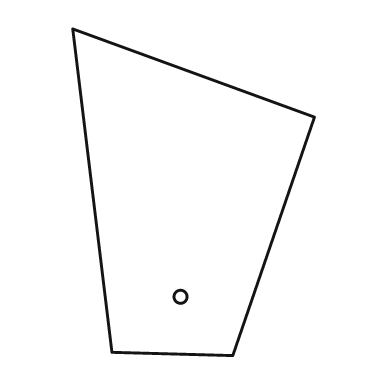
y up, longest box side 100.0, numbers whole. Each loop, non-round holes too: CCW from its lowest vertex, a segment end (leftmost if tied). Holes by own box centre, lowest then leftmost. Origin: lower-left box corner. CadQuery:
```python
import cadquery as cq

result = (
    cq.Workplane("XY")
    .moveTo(49.0, 0.0)
    .lineTo(74.0, 73.0)
    .lineTo(0.0, 100.0)
    .lineTo(12.0, 1.0)
    .close()
    .moveTo(33.0, 18.0)
    .circle(2.0)
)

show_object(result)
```